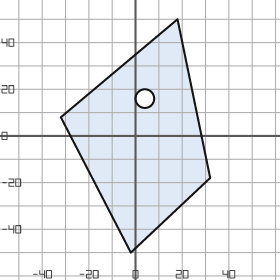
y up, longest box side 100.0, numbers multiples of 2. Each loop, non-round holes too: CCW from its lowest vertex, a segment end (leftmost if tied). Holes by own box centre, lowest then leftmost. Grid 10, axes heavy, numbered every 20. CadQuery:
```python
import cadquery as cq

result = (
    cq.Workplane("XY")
    .moveTo(-2.0, -50.0)
    .lineTo(32.0, -18.0)
    .lineTo(18.0, 50.0)
    .lineTo(-32.0, 8.0)
    .close()
    .moveTo(4.0, 16.0)
    .circle(4.0)
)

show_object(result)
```